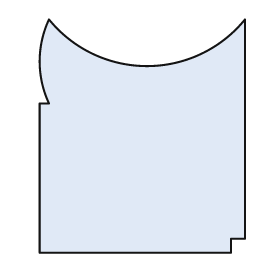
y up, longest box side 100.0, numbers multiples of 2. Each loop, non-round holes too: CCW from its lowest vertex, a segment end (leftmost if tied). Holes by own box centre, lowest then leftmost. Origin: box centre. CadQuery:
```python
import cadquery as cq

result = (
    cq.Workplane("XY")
    .moveTo(-44.0, -50.0)
    .lineTo(38.0, -50.0)
    .lineTo(38.0, -44.0)
    .lineTo(44.0, -44.0)
    .lineTo(44.0, 50.0)
    .threePointArc((2.0, 30.0), (-40.0, 50.0))
    .threePointArc((-44.0, 32.0), (-40.0, 14.0))
    .lineTo(-44.0, 14.0)
    .close()
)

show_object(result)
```